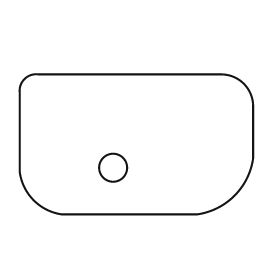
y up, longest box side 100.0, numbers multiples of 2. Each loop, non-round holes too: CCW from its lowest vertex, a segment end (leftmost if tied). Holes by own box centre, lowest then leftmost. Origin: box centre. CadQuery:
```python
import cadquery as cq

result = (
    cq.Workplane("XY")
    .moveTo(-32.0, -30.0)
    .lineTo(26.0, -30.0)
    .threePointArc((42.0, -22.0), (50.0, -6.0))
    .lineTo(50.0, 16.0)
    .threePointArc((46.0, 26.0), (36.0, 30.0))
    .lineTo(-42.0, 30.0)
    .threePointArc((-48.0, 28.0), (-50.0, 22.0))
    .lineTo(-50.0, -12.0)
    .threePointArc((-44.0, -24.0), (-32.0, -30.0))
    .close()
    .moveTo(-10.0, -10.0)
    .circle(6.0)
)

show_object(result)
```